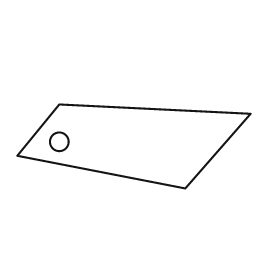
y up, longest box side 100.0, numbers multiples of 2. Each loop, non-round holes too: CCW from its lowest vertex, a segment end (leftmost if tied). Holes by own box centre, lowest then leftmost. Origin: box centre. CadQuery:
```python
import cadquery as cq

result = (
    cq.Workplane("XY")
    .moveTo(22.0, -18.0)
    .lineTo(50.0, 14.0)
    .lineTo(-32.0, 18.0)
    .lineTo(-50.0, -4.0)
    .close()
    .moveTo(-32.0, 2.0)
    .circle(4.0)
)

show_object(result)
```